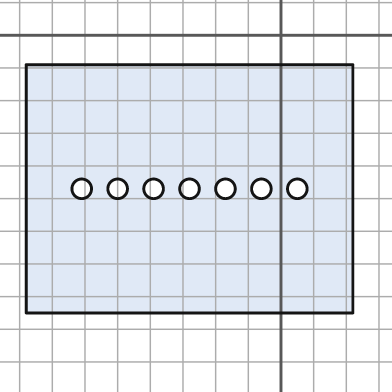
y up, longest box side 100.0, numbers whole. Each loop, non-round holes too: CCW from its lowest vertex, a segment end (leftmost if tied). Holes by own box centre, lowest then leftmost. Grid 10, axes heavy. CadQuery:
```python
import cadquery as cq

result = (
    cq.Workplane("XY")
    .moveTo(-78.0, -85.0)
    .lineTo(22.0, -85.0)
    .lineTo(22.0, -9.0)
    .lineTo(-78.0, -9.0)
    .close()
    .moveTo(-61.0, -47.0)
    .circle(3.0)
    .moveTo(-50.0, -47.0)
    .circle(3.0)
    .moveTo(-39.0, -47.0)
    .circle(3.0)
    .moveTo(-28.0, -47.0)
    .circle(3.0)
    .moveTo(-17.0, -47.0)
    .circle(3.0)
    .moveTo(-6.0, -47.0)
    .circle(3.0)
    .moveTo(5.0, -47.0)
    .circle(3.0)
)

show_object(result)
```